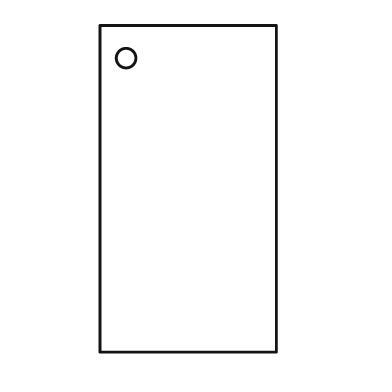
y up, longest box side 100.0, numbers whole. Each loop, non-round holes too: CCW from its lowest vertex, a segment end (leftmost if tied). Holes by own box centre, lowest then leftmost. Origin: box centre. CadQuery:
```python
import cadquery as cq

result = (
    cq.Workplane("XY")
    .moveTo(-27.0, -50.0)
    .lineTo(27.0, -50.0)
    .lineTo(27.0, 50.0)
    .lineTo(-27.0, 50.0)
    .close()
    .moveTo(-19.0, 40.0)
    .circle(3.0)
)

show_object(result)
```